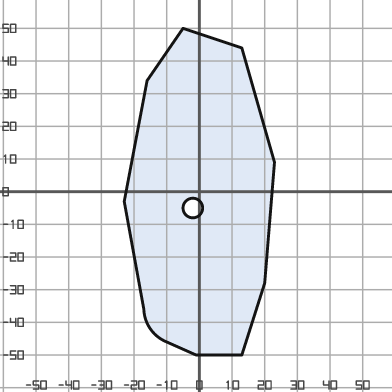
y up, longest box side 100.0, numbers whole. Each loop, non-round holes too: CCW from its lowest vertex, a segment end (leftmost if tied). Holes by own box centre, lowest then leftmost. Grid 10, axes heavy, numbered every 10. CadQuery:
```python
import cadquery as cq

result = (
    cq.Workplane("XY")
    .moveTo(-1.0, -50.0)
    .lineTo(13.0, -50.0)
    .lineTo(20.0, -28.0)
    .lineTo(23.0, 9.0)
    .lineTo(13.0, 44.0)
    .lineTo(-5.0, 50.0)
    .lineTo(-16.0, 34.0)
    .lineTo(-23.0, -3.0)
    .lineTo(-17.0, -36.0)
    .threePointArc((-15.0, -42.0), (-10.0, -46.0))
    .close()
    .moveTo(-2.0, -5.0)
    .circle(3.0)
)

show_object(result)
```